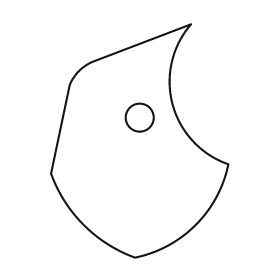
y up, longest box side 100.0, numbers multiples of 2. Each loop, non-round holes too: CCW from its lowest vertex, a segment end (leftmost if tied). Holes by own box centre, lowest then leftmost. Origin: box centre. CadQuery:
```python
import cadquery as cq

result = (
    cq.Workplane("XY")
    .moveTo(-2.0, -50.0)
    .threePointArc((24.0, -36.0), (38.0, -10.0))
    .threePointArc((14.0, 16.0), (22.0, 50.0))
    .lineTo(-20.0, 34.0)
    .threePointArc((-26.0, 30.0), (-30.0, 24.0))
    .lineTo(-38.0, -14.0)
    .threePointArc((-24.0, -36.0), (-2.0, -50.0))
    .close()
    .moveTo(0.0, 10.0)
    .circle(6.0)
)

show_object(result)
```